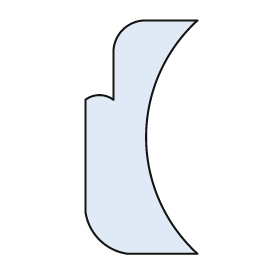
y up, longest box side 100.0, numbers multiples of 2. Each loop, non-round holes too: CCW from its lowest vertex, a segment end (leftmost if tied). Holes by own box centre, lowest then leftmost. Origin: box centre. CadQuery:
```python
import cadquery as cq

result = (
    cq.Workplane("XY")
    .moveTo(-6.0, -50.0)
    .lineTo(24.0, -50.0)
    .threePointArc((2.0, 0.0), (24.0, 50.0))
    .lineTo(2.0, 50.0)
    .threePointArc((-8.0, 46.0), (-12.0, 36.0))
    .lineTo(-12.0, 16.0)
    .threePointArc((-18.0, 18.0), (-24.0, 16.0))
    .lineTo(-24.0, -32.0)
    .threePointArc((-18.0, -44.0), (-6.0, -50.0))
    .close()
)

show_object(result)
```